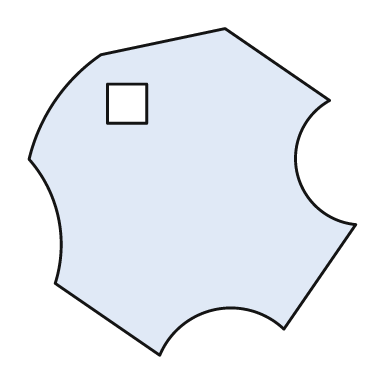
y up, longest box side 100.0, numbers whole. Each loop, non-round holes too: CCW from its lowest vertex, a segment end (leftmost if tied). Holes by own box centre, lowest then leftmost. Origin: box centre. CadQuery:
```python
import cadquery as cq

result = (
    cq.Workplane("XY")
    .moveTo(-10.0, -50.0)
    .threePointArc((7.0, -36.0), (28.0, -42.0))
    .lineTo(50.0, -10.0)
    .threePointArc((32.0, 6.0), (42.0, 28.0))
    .lineTo(10.0, 50.0)
    .lineTo(-28.0, 42.0)
    .threePointArc((-42.0, 28.0), (-50.0, 10.0))
    .threePointArc((-41.0, -8.0), (-42.0, -28.0))
    .close()
    .moveTo(-26.0, 21.0)
    .lineTo(-14.0, 21.0)
    .lineTo(-14.0, 33.0)
    .lineTo(-26.0, 33.0)
    .close()
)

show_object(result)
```